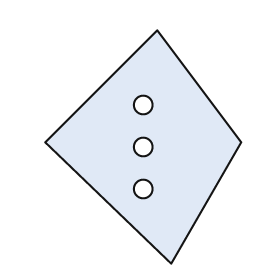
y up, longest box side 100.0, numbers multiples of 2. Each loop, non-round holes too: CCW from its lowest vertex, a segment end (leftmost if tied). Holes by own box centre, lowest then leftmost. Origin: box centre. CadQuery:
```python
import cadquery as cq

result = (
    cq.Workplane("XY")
    .moveTo(12.0, -50.0)
    .lineTo(42.0, 2.0)
    .lineTo(6.0, 50.0)
    .lineTo(-42.0, 2.0)
    .close()
    .moveTo(0.0, -18.0)
    .circle(4.0)
    .moveTo(0.0, 0.0)
    .circle(4.0)
    .moveTo(0.0, 18.0)
    .circle(4.0)
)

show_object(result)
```